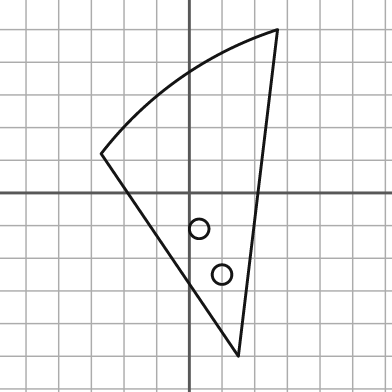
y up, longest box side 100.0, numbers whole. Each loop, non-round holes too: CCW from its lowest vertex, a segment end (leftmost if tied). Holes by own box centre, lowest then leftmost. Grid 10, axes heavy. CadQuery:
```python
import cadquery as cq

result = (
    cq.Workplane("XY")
    .moveTo(15.0, -50.0)
    .lineTo(27.0, 50.0)
    .threePointArc((-3.0, 35.0), (-27.0, 12.0))
    .close()
    .moveTo(10.0, -25.0)
    .circle(3.0)
    .moveTo(3.0, -11.0)
    .circle(3.0)
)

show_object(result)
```